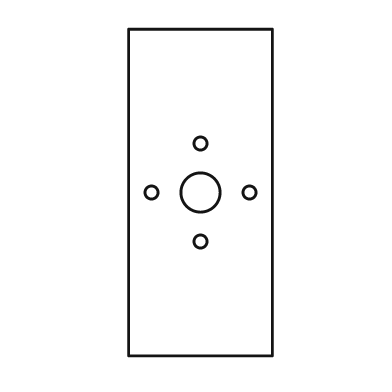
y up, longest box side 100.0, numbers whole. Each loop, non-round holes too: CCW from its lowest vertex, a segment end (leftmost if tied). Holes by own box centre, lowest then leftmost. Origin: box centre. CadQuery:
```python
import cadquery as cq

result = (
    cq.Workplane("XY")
    .moveTo(-22.0, -50.0)
    .lineTo(22.0, -50.0)
    .lineTo(22.0, 50.0)
    .lineTo(-22.0, 50.0)
    .close()
    .moveTo(0.0, -15.0)
    .circle(2.0)
    .moveTo(-15.0, 0.0)
    .circle(2.0)
    .moveTo(0.0, 0.0)
    .circle(6.0)
    .moveTo(15.0, 0.0)
    .circle(2.0)
    .moveTo(0.0, 15.0)
    .circle(2.0)
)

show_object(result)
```